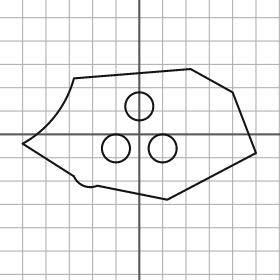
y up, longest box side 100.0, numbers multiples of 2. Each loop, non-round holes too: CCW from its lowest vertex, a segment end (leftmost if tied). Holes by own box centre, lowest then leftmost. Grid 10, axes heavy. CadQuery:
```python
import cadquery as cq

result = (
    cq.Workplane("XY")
    .moveTo(12.0, -28.0)
    .lineTo(50.0, -8.0)
    .lineTo(40.0, 18.0)
    .lineTo(22.0, 28.0)
    .lineTo(-28.0, 24.0)
    .threePointArc((-36.0, 8.0), (-50.0, -4.0))
    .lineTo(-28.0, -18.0)
    .threePointArc((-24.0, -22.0), (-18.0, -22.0))
    .close()
    .moveTo(-10.0, -6.0)
    .circle(6.0)
    .moveTo(10.0, -6.0)
    .circle(6.0)
    .moveTo(0.0, 12.0)
    .circle(6.0)
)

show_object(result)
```